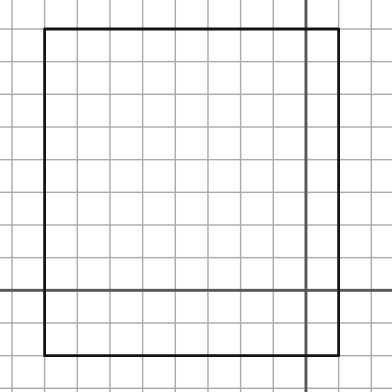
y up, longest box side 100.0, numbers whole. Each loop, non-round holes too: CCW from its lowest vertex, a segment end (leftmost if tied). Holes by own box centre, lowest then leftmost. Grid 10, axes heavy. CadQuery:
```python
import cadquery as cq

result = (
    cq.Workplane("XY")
    .moveTo(-80.0, -20.0)
    .lineTo(10.0, -20.0)
    .lineTo(10.0, 80.0)
    .lineTo(-80.0, 80.0)
    .close()
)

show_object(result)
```